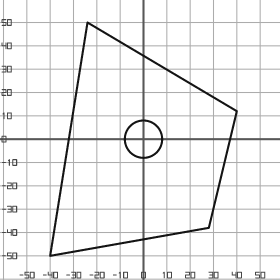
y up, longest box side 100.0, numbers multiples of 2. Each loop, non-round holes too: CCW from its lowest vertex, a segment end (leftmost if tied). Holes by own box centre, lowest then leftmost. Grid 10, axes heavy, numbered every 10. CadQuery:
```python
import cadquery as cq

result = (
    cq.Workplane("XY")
    .moveTo(-40.0, -50.0)
    .lineTo(28.0, -38.0)
    .lineTo(40.0, 12.0)
    .lineTo(-24.0, 50.0)
    .close()
    .moveTo(0.0, 0.0)
    .circle(8.0)
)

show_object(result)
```